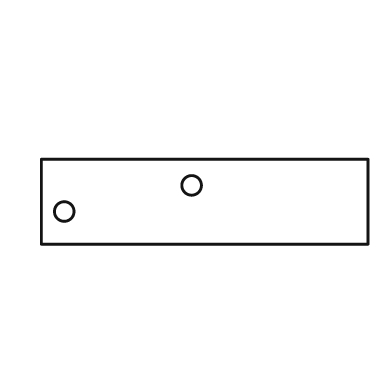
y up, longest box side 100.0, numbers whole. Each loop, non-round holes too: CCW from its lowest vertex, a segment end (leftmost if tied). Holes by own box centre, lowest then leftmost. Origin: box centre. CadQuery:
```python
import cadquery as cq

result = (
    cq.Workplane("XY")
    .moveTo(-50.0, -13.0)
    .lineTo(50.0, -13.0)
    .lineTo(50.0, 13.0)
    .lineTo(-50.0, 13.0)
    .close()
    .moveTo(-43.0, -3.0)
    .circle(3.0)
    .moveTo(-4.0, 5.0)
    .circle(3.0)
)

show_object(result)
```